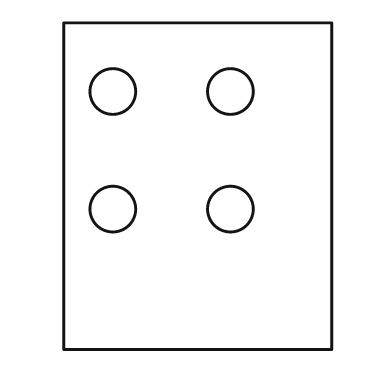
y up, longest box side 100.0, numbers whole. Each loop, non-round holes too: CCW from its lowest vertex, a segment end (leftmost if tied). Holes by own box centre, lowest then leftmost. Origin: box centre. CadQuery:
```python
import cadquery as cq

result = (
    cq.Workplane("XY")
    .moveTo(-41.0, -50.0)
    .lineTo(41.0, -50.0)
    .lineTo(41.0, 50.0)
    .lineTo(-41.0, 50.0)
    .close()
    .moveTo(-26.0, -7.0)
    .circle(7.0)
    .moveTo(10.0, -7.0)
    .circle(7.0)
    .moveTo(-26.0, 29.0)
    .circle(7.0)
    .moveTo(10.0, 29.0)
    .circle(7.0)
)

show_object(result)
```